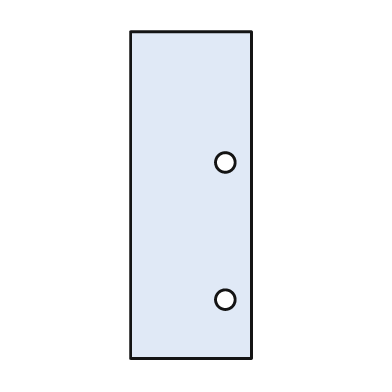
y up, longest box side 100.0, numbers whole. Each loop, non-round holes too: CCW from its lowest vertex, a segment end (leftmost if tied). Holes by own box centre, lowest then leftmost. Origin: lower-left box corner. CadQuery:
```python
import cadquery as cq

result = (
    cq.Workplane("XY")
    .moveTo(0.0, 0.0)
    .lineTo(37.0, 0.0)
    .lineTo(37.0, 100.0)
    .lineTo(0.0, 100.0)
    .close()
    .moveTo(29.0, 18.0)
    .circle(3.0)
    .moveTo(29.0, 60.0)
    .circle(3.0)
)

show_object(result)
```